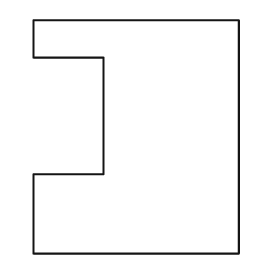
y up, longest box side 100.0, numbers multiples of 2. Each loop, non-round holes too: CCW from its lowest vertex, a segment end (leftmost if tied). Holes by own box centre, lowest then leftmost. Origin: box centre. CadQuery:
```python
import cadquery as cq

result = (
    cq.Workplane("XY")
    .moveTo(-44.0, -50.0)
    .lineTo(44.0, -50.0)
    .lineTo(44.0, 50.0)
    .lineTo(-44.0, 50.0)
    .lineTo(-44.0, 34.0)
    .lineTo(-14.0, 34.0)
    .lineTo(-14.0, -16.0)
    .lineTo(-44.0, -16.0)
    .close()
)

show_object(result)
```